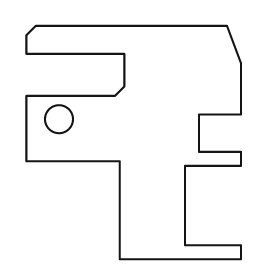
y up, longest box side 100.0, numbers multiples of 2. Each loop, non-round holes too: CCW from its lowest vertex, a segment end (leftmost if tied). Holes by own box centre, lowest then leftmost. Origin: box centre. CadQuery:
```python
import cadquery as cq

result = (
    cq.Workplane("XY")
    .moveTo(-6.0, -50.0)
    .lineTo(46.0, -50.0)
    .lineTo(46.0, -44.0)
    .lineTo(22.0, -44.0)
    .lineTo(22.0, -10.0)
    .lineTo(46.0, -10.0)
    .lineTo(46.0, -4.0)
    .lineTo(28.0, -4.0)
    .lineTo(28.0, 12.0)
    .lineTo(46.0, 12.0)
    .lineTo(46.0, 34.0)
    .lineTo(40.0, 50.0)
    .lineTo(-42.0, 50.0)
    .lineTo(-46.0, 46.0)
    .lineTo(-46.0, 38.0)
    .lineTo(-4.0, 38.0)
    .lineTo(-4.0, 24.0)
    .lineTo(-8.0, 20.0)
    .lineTo(-46.0, 20.0)
    .lineTo(-46.0, -8.0)
    .lineTo(-6.0, -8.0)
    .close()
    .moveTo(-32.0, 10.0)
    .circle(6.0)
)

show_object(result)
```